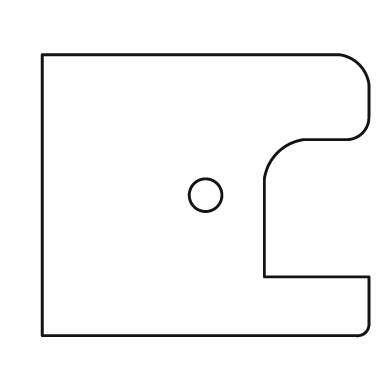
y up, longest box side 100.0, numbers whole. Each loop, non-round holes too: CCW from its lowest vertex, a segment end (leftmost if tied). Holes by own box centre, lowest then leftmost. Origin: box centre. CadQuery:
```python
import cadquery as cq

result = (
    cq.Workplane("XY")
    .moveTo(-50.0, -43.0)
    .lineTo(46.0, -43.0)
    .threePointArc((49.0, -42.0), (50.0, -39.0))
    .lineTo(50.0, -25.0)
    .lineTo(18.0, -25.0)
    .lineTo(18.0, 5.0)
    .threePointArc((22.0, 13.0), (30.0, 17.0))
    .lineTo(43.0, 17.0)
    .threePointArc((48.0, 19.0), (50.0, 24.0))
    .lineTo(50.0, 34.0)
    .threePointArc((47.0, 40.0), (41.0, 43.0))
    .lineTo(-50.0, 43.0)
    .close()
    .moveTo(0.0, 0.0)
    .circle(5.0)
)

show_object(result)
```